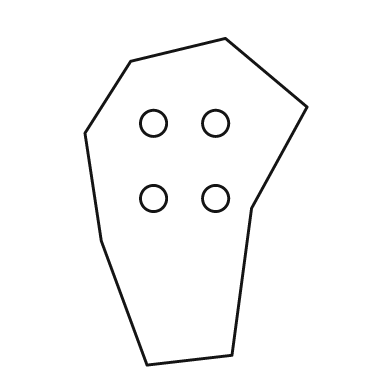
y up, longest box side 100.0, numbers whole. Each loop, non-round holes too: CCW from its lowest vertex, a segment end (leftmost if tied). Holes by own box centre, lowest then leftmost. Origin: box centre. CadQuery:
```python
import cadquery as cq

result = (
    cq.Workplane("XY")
    .moveTo(-15.0, -50.0)
    .lineTo(11.0, -47.0)
    .lineTo(17.0, -2.0)
    .lineTo(34.0, 29.0)
    .lineTo(9.0, 50.0)
    .lineTo(-20.0, 43.0)
    .lineTo(-34.0, 21.0)
    .lineTo(-29.0, -12.0)
    .close()
    .moveTo(-13.0, 1.0)
    .circle(4.0)
    .moveTo(6.0, 1.0)
    .circle(4.0)
    .moveTo(-13.0, 24.0)
    .circle(4.0)
    .moveTo(6.0, 24.0)
    .circle(4.0)
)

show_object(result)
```